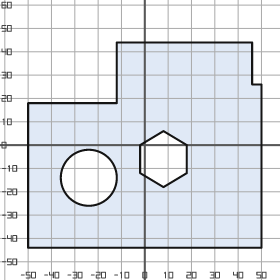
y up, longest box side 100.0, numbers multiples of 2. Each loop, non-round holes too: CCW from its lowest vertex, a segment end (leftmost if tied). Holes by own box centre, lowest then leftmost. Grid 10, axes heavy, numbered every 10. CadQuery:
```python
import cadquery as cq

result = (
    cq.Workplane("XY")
    .moveTo(-50.0, -44.0)
    .lineTo(50.0, -44.0)
    .lineTo(50.0, 26.0)
    .lineTo(46.0, 26.0)
    .lineTo(46.0, 44.0)
    .lineTo(-12.0, 44.0)
    .lineTo(-12.0, 18.0)
    .lineTo(-50.0, 18.0)
    .close()
    .moveTo(-24.0, -14.0)
    .circle(12.0)
    .moveTo(8.0, -18.0)
    .lineTo(18.0, -12.0)
    .lineTo(18.0, 0.0)
    .lineTo(8.0, 6.0)
    .lineTo(-2.0, 0.0)
    .lineTo(-2.0, -12.0)
    .close()
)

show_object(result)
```